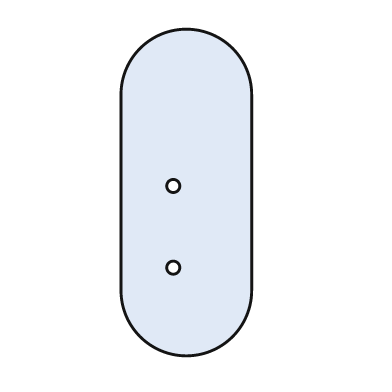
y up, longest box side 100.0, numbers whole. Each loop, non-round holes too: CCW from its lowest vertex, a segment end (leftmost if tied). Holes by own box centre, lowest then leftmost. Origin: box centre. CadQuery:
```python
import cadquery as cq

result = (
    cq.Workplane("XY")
    .moveTo(-20.0, -30.0)
    .threePointArc((0.0, -50.0), (20.0, -30.0))
    .lineTo(20.0, 30.0)
    .threePointArc((0.0, 50.0), (-20.0, 30.0))
    .close()
    .moveTo(-4.0, -23.0)
    .circle(2.0)
    .moveTo(-4.0, 2.0)
    .circle(2.0)
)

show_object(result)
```